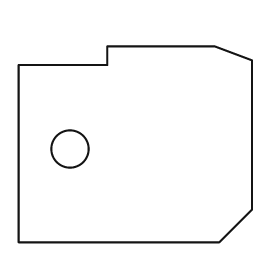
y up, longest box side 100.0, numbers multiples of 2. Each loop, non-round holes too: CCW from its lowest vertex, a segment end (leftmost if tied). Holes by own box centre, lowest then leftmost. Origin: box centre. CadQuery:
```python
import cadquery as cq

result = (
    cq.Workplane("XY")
    .moveTo(-50.0, -42.0)
    .lineTo(36.0, -42.0)
    .lineTo(50.0, -28.0)
    .lineTo(50.0, 36.0)
    .lineTo(34.0, 42.0)
    .lineTo(-12.0, 42.0)
    .lineTo(-12.0, 34.0)
    .lineTo(-50.0, 34.0)
    .close()
    .moveTo(-28.0, -2.0)
    .circle(8.0)
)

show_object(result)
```